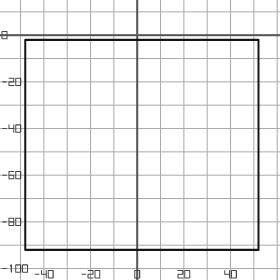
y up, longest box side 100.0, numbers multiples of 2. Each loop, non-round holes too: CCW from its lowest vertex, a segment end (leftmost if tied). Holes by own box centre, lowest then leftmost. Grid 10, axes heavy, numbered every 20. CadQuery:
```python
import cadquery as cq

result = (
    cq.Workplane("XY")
    .moveTo(-48.0, -92.0)
    .lineTo(52.0, -92.0)
    .lineTo(52.0, -2.0)
    .lineTo(-48.0, -2.0)
    .close()
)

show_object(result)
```